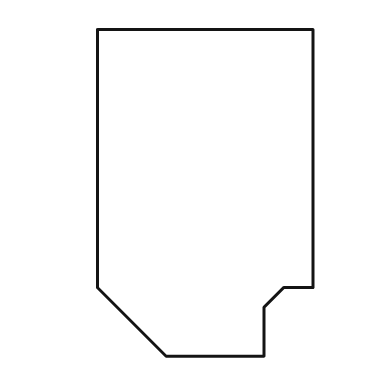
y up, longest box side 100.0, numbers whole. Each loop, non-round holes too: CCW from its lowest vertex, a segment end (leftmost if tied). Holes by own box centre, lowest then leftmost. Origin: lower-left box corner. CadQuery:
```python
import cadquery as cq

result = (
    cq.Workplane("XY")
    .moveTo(21.0, 0.0)
    .lineTo(51.0, 0.0)
    .lineTo(51.0, 15.0)
    .lineTo(57.0, 21.0)
    .lineTo(66.0, 21.0)
    .lineTo(66.0, 100.0)
    .lineTo(0.0, 100.0)
    .lineTo(0.0, 21.0)
    .close()
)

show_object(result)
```